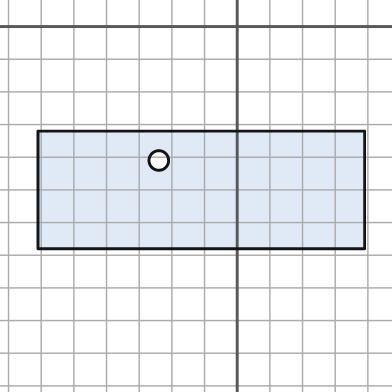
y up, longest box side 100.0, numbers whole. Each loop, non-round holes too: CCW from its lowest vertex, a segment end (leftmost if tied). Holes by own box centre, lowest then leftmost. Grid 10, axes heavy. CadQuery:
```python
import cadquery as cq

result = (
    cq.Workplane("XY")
    .moveTo(-61.0, -68.0)
    .lineTo(39.0, -68.0)
    .lineTo(39.0, -32.0)
    .lineTo(-61.0, -32.0)
    .close()
    .moveTo(-24.0, -41.0)
    .circle(3.0)
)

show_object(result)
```